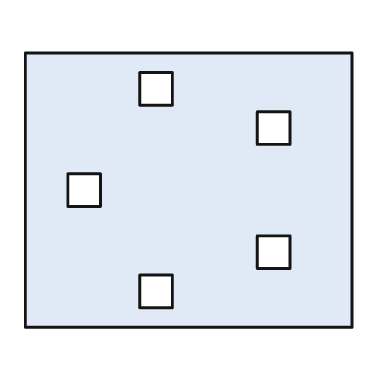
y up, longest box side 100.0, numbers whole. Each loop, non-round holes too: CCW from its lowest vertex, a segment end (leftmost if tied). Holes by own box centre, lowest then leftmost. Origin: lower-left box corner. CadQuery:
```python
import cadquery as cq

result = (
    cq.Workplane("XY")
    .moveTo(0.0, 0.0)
    .lineTo(100.0, 0.0)
    .lineTo(100.0, 84.0)
    .lineTo(0.0, 84.0)
    .close()
    .moveTo(35.0, 6.0)
    .lineTo(45.0, 6.0)
    .lineTo(45.0, 16.0)
    .lineTo(35.0, 16.0)
    .close()
    .moveTo(71.0, 18.0)
    .lineTo(81.0, 18.0)
    .lineTo(81.0, 28.0)
    .lineTo(71.0, 28.0)
    .close()
    .moveTo(13.0, 37.0)
    .lineTo(23.0, 37.0)
    .lineTo(23.0, 47.0)
    .lineTo(13.0, 47.0)
    .close()
    .moveTo(71.0, 56.0)
    .lineTo(81.0, 56.0)
    .lineTo(81.0, 66.0)
    .lineTo(71.0, 66.0)
    .close()
    .moveTo(35.0, 68.0)
    .lineTo(45.0, 68.0)
    .lineTo(45.0, 78.0)
    .lineTo(35.0, 78.0)
    .close()
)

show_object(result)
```